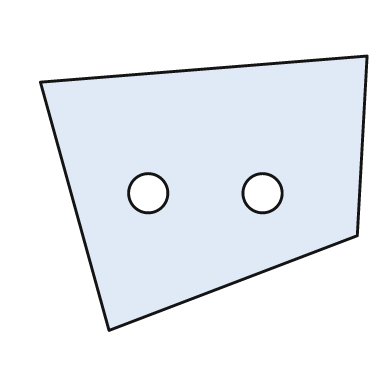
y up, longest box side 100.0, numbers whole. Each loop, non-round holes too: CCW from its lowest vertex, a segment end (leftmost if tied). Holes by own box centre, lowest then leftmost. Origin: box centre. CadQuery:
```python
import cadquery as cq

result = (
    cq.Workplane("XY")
    .moveTo(-29.0, -42.0)
    .lineTo(47.0, -13.0)
    .lineTo(50.0, 42.0)
    .lineTo(-50.0, 34.0)
    .close()
    .moveTo(-17.0, 0.0)
    .circle(6.0)
    .moveTo(18.0, 0.0)
    .circle(6.0)
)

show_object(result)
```